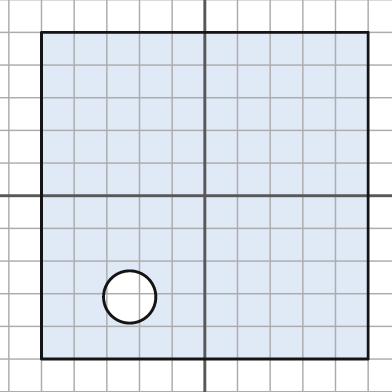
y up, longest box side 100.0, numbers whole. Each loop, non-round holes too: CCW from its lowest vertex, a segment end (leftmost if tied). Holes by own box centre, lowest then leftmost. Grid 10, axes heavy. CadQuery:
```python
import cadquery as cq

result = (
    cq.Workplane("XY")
    .moveTo(-50.0, -50.0)
    .lineTo(50.0, -50.0)
    .lineTo(50.0, 50.0)
    .lineTo(-50.0, 50.0)
    .close()
    .moveTo(-23.0, -31.0)
    .circle(8.0)
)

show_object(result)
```